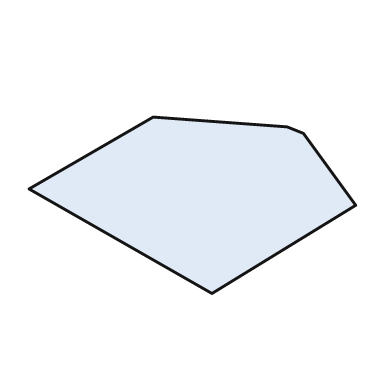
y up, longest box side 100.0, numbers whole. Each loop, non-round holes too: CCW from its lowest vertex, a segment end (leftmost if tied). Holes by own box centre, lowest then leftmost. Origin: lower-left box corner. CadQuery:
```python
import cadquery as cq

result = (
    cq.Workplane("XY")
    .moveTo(56.0, 0.0)
    .lineTo(100.0, 27.0)
    .lineTo(84.0, 49.0)
    .lineTo(79.0, 51.0)
    .lineTo(38.0, 54.0)
    .lineTo(0.0, 32.0)
    .close()
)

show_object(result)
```